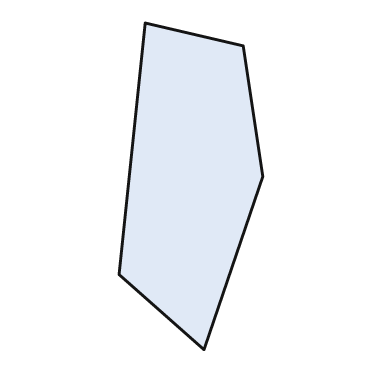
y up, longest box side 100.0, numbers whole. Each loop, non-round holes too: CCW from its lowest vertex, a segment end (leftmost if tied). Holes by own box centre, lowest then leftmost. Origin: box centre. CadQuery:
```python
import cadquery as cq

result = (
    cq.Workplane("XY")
    .moveTo(4.0, -50.0)
    .lineTo(22.0, 3.0)
    .lineTo(16.0, 43.0)
    .lineTo(-14.0, 50.0)
    .lineTo(-22.0, -27.0)
    .close()
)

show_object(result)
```